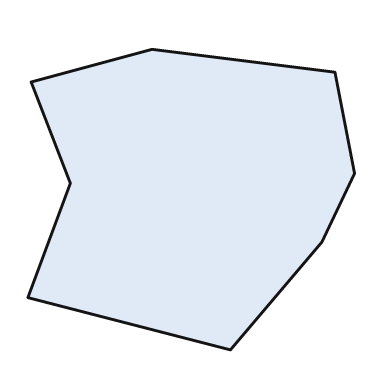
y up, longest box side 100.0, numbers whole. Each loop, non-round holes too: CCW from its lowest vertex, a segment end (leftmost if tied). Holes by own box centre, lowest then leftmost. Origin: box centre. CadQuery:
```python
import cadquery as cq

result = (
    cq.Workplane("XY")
    .moveTo(12.0, -46.0)
    .lineTo(40.0, -13.0)
    .lineTo(50.0, 8.0)
    .lineTo(44.0, 39.0)
    .lineTo(-12.0, 46.0)
    .lineTo(-49.0, 36.0)
    .lineTo(-37.0, 5.0)
    .lineTo(-50.0, -30.0)
    .close()
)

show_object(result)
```